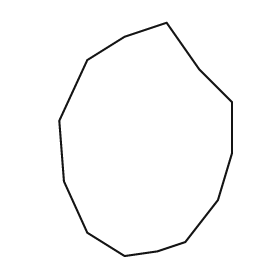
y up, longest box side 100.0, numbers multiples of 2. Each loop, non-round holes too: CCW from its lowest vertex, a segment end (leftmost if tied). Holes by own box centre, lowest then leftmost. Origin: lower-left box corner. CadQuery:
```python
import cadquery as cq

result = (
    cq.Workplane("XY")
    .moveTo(28.0, 0.0)
    .lineTo(42.0, 2.0)
    .lineTo(54.0, 6.0)
    .lineTo(68.0, 24.0)
    .lineTo(74.0, 44.0)
    .lineTo(74.0, 66.0)
    .lineTo(60.0, 80.0)
    .lineTo(46.0, 100.0)
    .lineTo(28.0, 94.0)
    .lineTo(12.0, 84.0)
    .lineTo(0.0, 58.0)
    .lineTo(2.0, 32.0)
    .lineTo(12.0, 10.0)
    .close()
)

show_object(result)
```